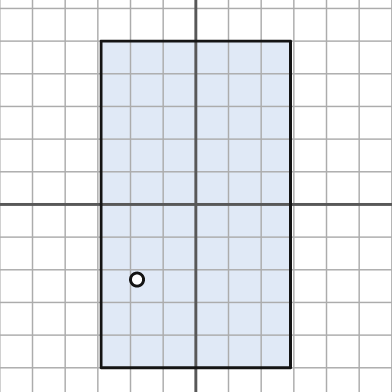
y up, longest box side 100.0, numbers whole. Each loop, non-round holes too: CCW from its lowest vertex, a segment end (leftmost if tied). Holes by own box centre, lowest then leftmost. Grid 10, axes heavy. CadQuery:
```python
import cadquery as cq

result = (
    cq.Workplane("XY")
    .moveTo(-29.0, -50.0)
    .lineTo(29.0, -50.0)
    .lineTo(29.0, 50.0)
    .lineTo(-29.0, 50.0)
    .close()
    .moveTo(-18.0, -23.0)
    .circle(2.0)
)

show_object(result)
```